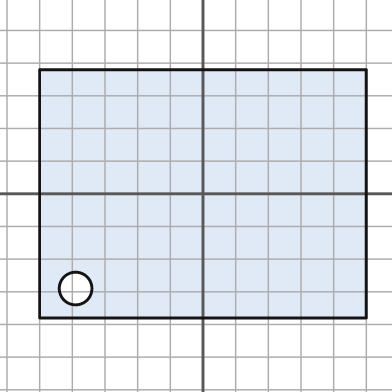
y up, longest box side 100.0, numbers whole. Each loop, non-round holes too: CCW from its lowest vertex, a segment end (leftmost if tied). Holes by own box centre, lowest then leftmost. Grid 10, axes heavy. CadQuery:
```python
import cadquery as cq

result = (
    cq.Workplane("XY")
    .moveTo(-50.0, -38.0)
    .lineTo(50.0, -38.0)
    .lineTo(50.0, 38.0)
    .lineTo(-50.0, 38.0)
    .close()
    .moveTo(-39.0, -29.0)
    .circle(5.0)
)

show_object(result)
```